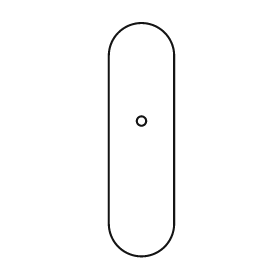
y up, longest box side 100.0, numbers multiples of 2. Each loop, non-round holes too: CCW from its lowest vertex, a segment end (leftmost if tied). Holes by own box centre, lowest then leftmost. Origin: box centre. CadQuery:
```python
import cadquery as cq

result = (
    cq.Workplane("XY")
    .moveTo(-14.0, -36.0)
    .threePointArc((0.0, -50.0), (14.0, -36.0))
    .lineTo(14.0, 36.0)
    .threePointArc((0.0, 50.0), (-14.0, 36.0))
    .close()
    .moveTo(0.0, 8.0)
    .circle(2.0)
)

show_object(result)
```